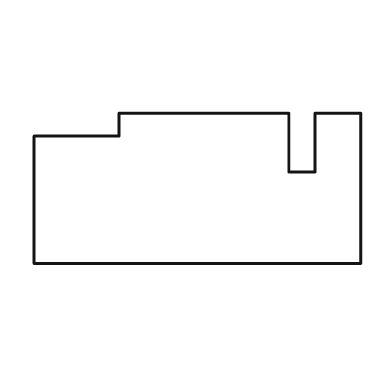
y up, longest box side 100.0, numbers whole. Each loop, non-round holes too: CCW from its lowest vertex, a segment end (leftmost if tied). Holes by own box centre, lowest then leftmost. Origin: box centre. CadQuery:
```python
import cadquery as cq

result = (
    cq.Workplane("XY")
    .moveTo(-50.0, -23.0)
    .lineTo(50.0, -23.0)
    .lineTo(50.0, 23.0)
    .lineTo(36.0, 23.0)
    .lineTo(36.0, 5.0)
    .lineTo(28.0, 5.0)
    .lineTo(28.0, 23.0)
    .lineTo(-24.0, 23.0)
    .lineTo(-24.0, 16.0)
    .lineTo(-50.0, 16.0)
    .close()
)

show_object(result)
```